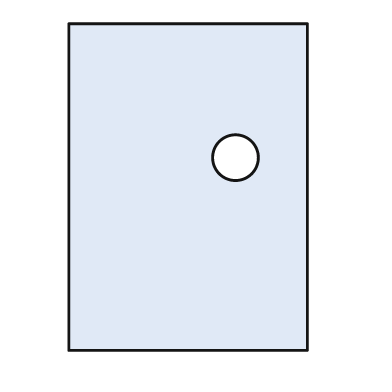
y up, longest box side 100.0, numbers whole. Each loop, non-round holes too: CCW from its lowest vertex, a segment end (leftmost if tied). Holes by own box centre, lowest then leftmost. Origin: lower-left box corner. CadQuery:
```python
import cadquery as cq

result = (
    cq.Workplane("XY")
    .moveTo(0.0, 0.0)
    .lineTo(73.0, 0.0)
    .lineTo(73.0, 100.0)
    .lineTo(0.0, 100.0)
    .close()
    .moveTo(51.0, 59.0)
    .circle(7.0)
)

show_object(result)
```